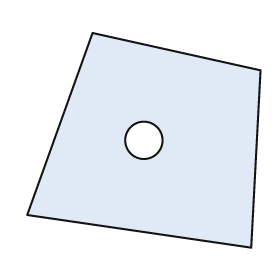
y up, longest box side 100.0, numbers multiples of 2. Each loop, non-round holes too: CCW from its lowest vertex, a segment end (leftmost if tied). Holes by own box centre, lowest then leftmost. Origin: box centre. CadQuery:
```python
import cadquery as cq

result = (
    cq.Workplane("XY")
    .moveTo(46.0, -46.0)
    .lineTo(50.0, 30.0)
    .lineTo(-22.0, 46.0)
    .lineTo(-50.0, -32.0)
    .close()
    .moveTo(0.0, 0.0)
    .circle(8.0)
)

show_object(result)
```